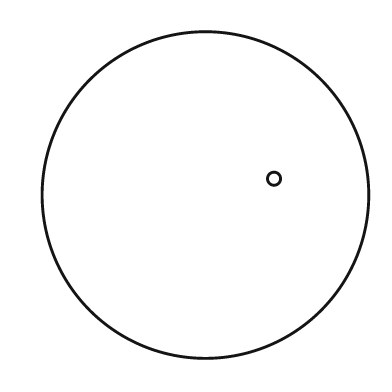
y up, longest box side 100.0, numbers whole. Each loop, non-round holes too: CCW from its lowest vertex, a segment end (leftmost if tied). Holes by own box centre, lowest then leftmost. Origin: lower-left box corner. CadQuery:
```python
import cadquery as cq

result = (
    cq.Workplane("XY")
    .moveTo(50.0, 50.0)
    .circle(50.0)
    .moveTo(71.0, 55.0)
    .circle(2.0)
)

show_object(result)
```